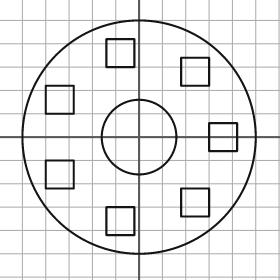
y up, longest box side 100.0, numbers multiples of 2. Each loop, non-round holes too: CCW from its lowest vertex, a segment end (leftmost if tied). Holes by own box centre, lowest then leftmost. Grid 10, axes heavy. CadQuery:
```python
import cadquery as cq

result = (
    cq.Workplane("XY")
    .moveTo(0.0, 0.0)
    .circle(50.0)
    .moveTo(-14.0, -42.0)
    .lineTo(-2.0, -42.0)
    .lineTo(-2.0, -30.0)
    .lineTo(-14.0, -30.0)
    .close()
    .moveTo(18.0, -34.0)
    .lineTo(30.0, -34.0)
    .lineTo(30.0, -22.0)
    .lineTo(18.0, -22.0)
    .close()
    .moveTo(-40.0, -22.0)
    .lineTo(-28.0, -22.0)
    .lineTo(-28.0, -10.0)
    .lineTo(-40.0, -10.0)
    .close()
    .moveTo(0.0, 0.0)
    .circle(16.0)
    .moveTo(30.0, -6.0)
    .lineTo(42.0, -6.0)
    .lineTo(42.0, 6.0)
    .lineTo(30.0, 6.0)
    .close()
    .moveTo(-40.0, 10.0)
    .lineTo(-28.0, 10.0)
    .lineTo(-28.0, 22.0)
    .lineTo(-40.0, 22.0)
    .close()
    .moveTo(18.0, 22.0)
    .lineTo(30.0, 22.0)
    .lineTo(30.0, 34.0)
    .lineTo(18.0, 34.0)
    .close()
    .moveTo(-14.0, 30.0)
    .lineTo(-2.0, 30.0)
    .lineTo(-2.0, 42.0)
    .lineTo(-14.0, 42.0)
    .close()
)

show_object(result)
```